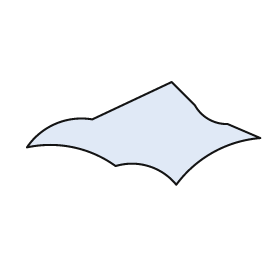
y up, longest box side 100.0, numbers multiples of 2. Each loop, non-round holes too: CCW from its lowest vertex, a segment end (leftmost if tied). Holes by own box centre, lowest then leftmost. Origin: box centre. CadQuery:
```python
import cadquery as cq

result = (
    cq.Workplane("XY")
    .moveTo(14.0, -22.0)
    .threePointArc((30.0, -8.0), (50.0, -2.0))
    .lineTo(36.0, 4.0)
    .threePointArc((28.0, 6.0), (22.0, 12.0))
    .lineTo(12.0, 22.0)
    .lineTo(-22.0, 6.0)
    .threePointArc((-38.0, 4.0), (-50.0, -6.0))
    .threePointArc((-30.0, -6.0), (-12.0, -14.0))
    .threePointArc((2.0, -14.0), (14.0, -22.0))
    .close()
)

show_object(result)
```